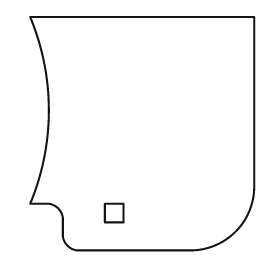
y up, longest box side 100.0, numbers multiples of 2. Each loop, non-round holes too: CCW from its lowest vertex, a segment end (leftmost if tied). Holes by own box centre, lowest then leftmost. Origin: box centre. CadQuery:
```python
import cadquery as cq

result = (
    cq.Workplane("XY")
    .moveTo(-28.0, -50.0)
    .lineTo(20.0, -50.0)
    .threePointArc((40.0, -42.0), (48.0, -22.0))
    .lineTo(48.0, 50.0)
    .lineTo(-48.0, 50.0)
    .threePointArc((-40.0, 10.0), (-48.0, -30.0))
    .lineTo(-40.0, -30.0)
    .threePointArc((-36.0, -32.0), (-34.0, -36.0))
    .lineTo(-34.0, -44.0)
    .threePointArc((-32.0, -48.0), (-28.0, -50.0))
    .close()
    .moveTo(-16.0, -38.0)
    .lineTo(-8.0, -38.0)
    .lineTo(-8.0, -30.0)
    .lineTo(-16.0, -30.0)
    .close()
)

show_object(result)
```